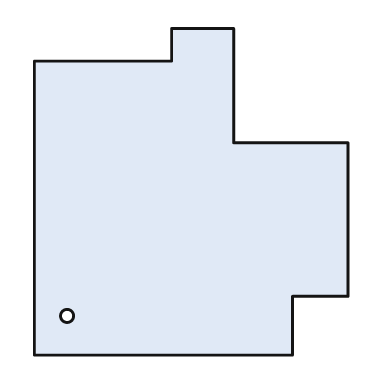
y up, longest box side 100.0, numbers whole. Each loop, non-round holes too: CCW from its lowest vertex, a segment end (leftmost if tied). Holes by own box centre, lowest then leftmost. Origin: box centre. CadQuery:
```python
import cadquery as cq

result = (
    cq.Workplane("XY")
    .moveTo(-48.0, -50.0)
    .lineTo(31.0, -50.0)
    .lineTo(31.0, -32.0)
    .lineTo(48.0, -32.0)
    .lineTo(48.0, 15.0)
    .lineTo(13.0, 15.0)
    .lineTo(13.0, 50.0)
    .lineTo(-6.0, 50.0)
    .lineTo(-6.0, 40.0)
    .lineTo(-48.0, 40.0)
    .close()
    .moveTo(-38.0, -38.0)
    .circle(2.0)
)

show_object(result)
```